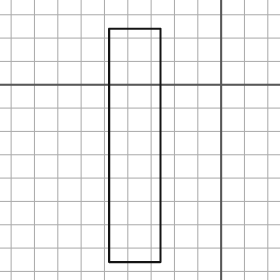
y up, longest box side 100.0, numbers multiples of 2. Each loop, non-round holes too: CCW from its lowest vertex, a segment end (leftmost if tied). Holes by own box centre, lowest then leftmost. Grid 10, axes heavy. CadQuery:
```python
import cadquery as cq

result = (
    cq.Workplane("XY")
    .moveTo(-48.0, -76.0)
    .lineTo(-26.0, -76.0)
    .lineTo(-26.0, 24.0)
    .lineTo(-48.0, 24.0)
    .close()
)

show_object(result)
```